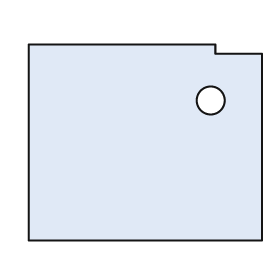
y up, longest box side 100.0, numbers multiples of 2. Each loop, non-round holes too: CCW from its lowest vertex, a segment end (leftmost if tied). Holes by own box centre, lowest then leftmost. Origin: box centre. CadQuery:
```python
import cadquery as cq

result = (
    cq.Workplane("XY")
    .moveTo(-50.0, -42.0)
    .lineTo(50.0, -42.0)
    .lineTo(50.0, 38.0)
    .lineTo(30.0, 38.0)
    .lineTo(30.0, 42.0)
    .lineTo(-50.0, 42.0)
    .close()
    .moveTo(28.0, 18.0)
    .circle(6.0)
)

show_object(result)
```